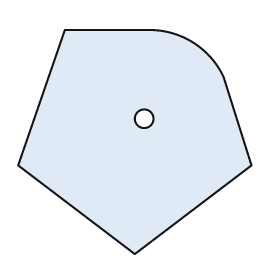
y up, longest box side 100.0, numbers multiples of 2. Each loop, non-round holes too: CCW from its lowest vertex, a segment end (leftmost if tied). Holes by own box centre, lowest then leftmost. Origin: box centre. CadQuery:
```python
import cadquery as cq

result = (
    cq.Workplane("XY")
    .moveTo(0.0, -48.0)
    .lineTo(50.0, -10.0)
    .lineTo(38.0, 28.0)
    .threePointArc((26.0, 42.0), (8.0, 48.0))
    .lineTo(-30.0, 48.0)
    .lineTo(-50.0, -10.0)
    .close()
    .moveTo(4.0, 10.0)
    .circle(4.0)
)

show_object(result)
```